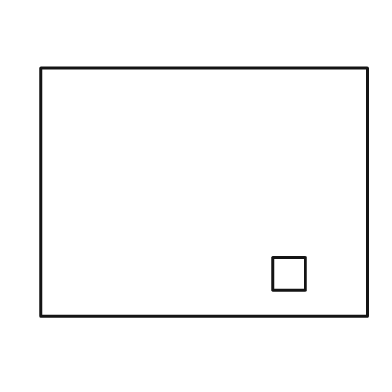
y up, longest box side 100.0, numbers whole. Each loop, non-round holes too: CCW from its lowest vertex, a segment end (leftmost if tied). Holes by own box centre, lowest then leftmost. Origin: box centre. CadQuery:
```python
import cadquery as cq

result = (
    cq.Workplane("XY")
    .moveTo(-50.0, -38.0)
    .lineTo(50.0, -38.0)
    .lineTo(50.0, 38.0)
    .lineTo(-50.0, 38.0)
    .close()
    .moveTo(21.0, -30.0)
    .lineTo(31.0, -30.0)
    .lineTo(31.0, -20.0)
    .lineTo(21.0, -20.0)
    .close()
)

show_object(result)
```